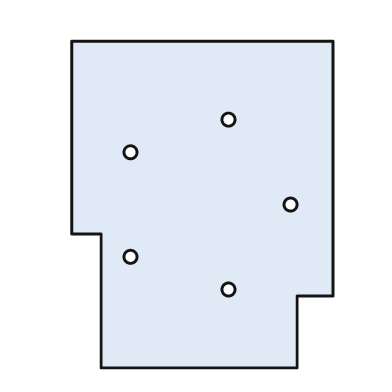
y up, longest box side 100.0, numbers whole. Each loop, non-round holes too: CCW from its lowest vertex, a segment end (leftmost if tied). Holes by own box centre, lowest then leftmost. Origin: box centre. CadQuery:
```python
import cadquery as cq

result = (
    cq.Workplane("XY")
    .moveTo(-31.0, -50.0)
    .lineTo(29.0, -50.0)
    .lineTo(29.0, -28.0)
    .lineTo(40.0, -28.0)
    .lineTo(40.0, 50.0)
    .lineTo(-40.0, 50.0)
    .lineTo(-40.0, -9.0)
    .lineTo(-31.0, -9.0)
    .close()
    .moveTo(8.0, -26.0)
    .circle(2.0)
    .moveTo(-22.0, -16.0)
    .circle(2.0)
    .moveTo(27.0, 0.0)
    .circle(2.0)
    .moveTo(-22.0, 16.0)
    .circle(2.0)
    .moveTo(8.0, 26.0)
    .circle(2.0)
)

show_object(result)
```